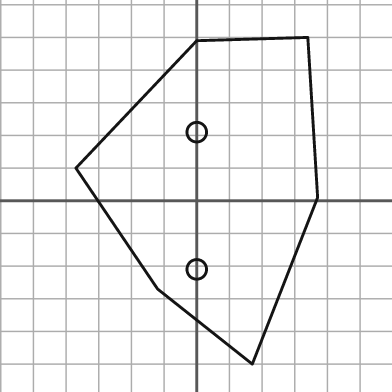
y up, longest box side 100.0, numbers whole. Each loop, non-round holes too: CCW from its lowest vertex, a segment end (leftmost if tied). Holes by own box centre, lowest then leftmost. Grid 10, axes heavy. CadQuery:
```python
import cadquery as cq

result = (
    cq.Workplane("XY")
    .moveTo(17.0, -50.0)
    .lineTo(37.0, 1.0)
    .lineTo(34.0, 50.0)
    .lineTo(0.0, 49.0)
    .lineTo(-37.0, 10.0)
    .lineTo(-12.0, -27.0)
    .close()
    .moveTo(0.0, -21.0)
    .circle(3.0)
    .moveTo(0.0, 21.0)
    .circle(3.0)
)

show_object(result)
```